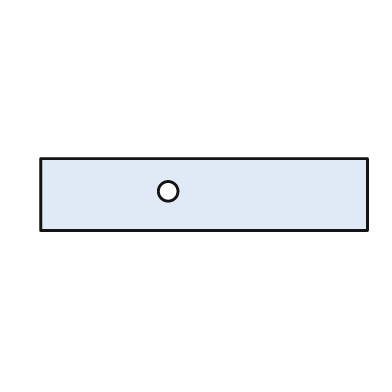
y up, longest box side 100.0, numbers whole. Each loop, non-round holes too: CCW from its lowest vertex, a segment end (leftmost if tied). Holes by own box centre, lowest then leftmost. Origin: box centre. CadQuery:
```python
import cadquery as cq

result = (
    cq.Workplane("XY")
    .moveTo(-50.0, -11.0)
    .lineTo(50.0, -11.0)
    .lineTo(50.0, 11.0)
    .lineTo(-50.0, 11.0)
    .close()
    .moveTo(-11.0, 1.0)
    .circle(3.0)
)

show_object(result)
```